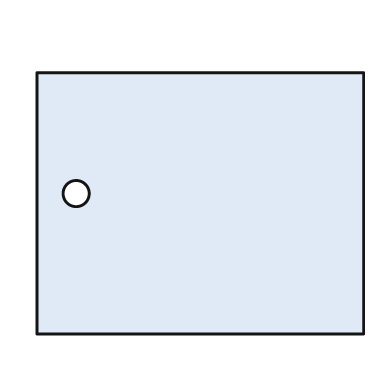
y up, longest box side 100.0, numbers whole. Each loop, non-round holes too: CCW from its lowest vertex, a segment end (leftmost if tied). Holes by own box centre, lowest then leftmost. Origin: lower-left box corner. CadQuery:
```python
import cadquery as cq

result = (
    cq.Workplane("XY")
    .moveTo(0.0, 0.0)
    .lineTo(100.0, 0.0)
    .lineTo(100.0, 80.0)
    .lineTo(0.0, 80.0)
    .close()
    .moveTo(12.0, 43.0)
    .circle(4.0)
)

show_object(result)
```